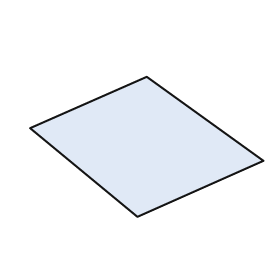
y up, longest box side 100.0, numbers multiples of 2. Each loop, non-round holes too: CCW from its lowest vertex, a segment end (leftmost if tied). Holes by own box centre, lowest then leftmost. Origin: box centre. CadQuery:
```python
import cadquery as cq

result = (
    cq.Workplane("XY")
    .moveTo(-4.0, -30.0)
    .lineTo(50.0, -6.0)
    .lineTo(0.0, 30.0)
    .lineTo(-50.0, 8.0)
    .close()
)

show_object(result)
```